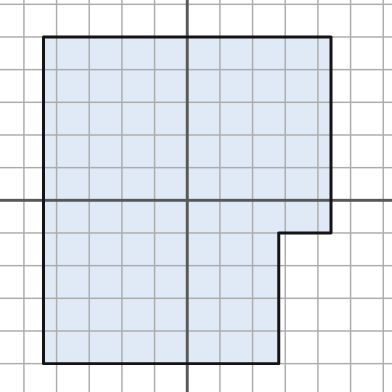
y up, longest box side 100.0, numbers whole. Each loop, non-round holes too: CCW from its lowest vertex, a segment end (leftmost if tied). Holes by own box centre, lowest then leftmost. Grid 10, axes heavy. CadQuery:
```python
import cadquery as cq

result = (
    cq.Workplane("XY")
    .moveTo(-44.0, -50.0)
    .lineTo(28.0, -50.0)
    .lineTo(28.0, -10.0)
    .lineTo(44.0, -10.0)
    .lineTo(44.0, 50.0)
    .lineTo(-44.0, 50.0)
    .close()
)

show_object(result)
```